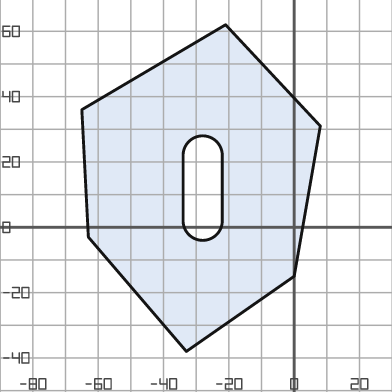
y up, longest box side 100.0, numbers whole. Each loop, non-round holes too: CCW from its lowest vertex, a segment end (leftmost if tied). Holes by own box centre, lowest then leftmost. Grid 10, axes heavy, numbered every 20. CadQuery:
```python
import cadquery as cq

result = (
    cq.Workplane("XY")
    .moveTo(-33.0, -38.0)
    .lineTo(0.0, -15.0)
    .lineTo(8.0, 31.0)
    .lineTo(-21.0, 62.0)
    .lineTo(-65.0, 36.0)
    .lineTo(-63.0, -3.0)
    .close()
    .moveTo(-34.0, 2.0)
    .threePointArc((-28.0, -4.0), (-22.0, 2.0))
    .lineTo(-22.0, 22.0)
    .threePointArc((-28.0, 28.0), (-34.0, 22.0))
    .close()
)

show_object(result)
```